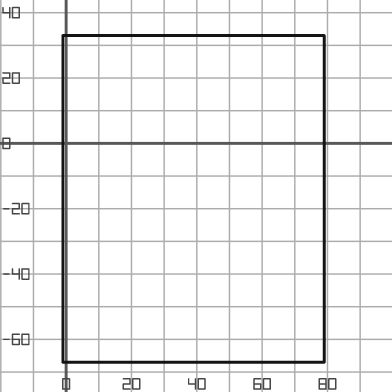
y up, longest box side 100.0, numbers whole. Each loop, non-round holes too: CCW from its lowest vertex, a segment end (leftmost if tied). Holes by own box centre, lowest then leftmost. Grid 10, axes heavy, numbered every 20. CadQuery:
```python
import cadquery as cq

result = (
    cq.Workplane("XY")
    .moveTo(-1.0, -67.0)
    .lineTo(79.0, -67.0)
    .lineTo(79.0, 33.0)
    .lineTo(-1.0, 33.0)
    .close()
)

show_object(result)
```